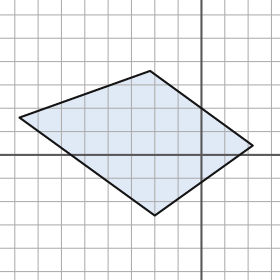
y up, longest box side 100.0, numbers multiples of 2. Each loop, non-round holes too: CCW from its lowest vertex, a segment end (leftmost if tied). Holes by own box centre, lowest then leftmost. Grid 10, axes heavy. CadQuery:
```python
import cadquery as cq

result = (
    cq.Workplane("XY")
    .moveTo(-20.0, -26.0)
    .lineTo(22.0, 4.0)
    .lineTo(-22.0, 36.0)
    .lineTo(-78.0, 16.0)
    .close()
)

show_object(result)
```